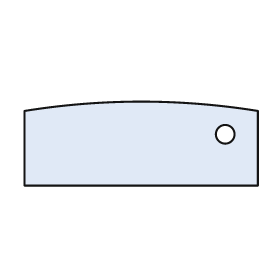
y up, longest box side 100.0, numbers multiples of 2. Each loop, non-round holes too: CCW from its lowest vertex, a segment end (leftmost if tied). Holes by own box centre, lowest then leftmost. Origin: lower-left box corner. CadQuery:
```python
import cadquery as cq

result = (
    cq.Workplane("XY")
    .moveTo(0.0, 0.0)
    .lineTo(100.0, 0.0)
    .lineTo(100.0, 32.0)
    .threePointArc((50.0, 36.0), (0.0, 32.0))
    .close()
    .moveTo(86.0, 22.0)
    .circle(4.0)
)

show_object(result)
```